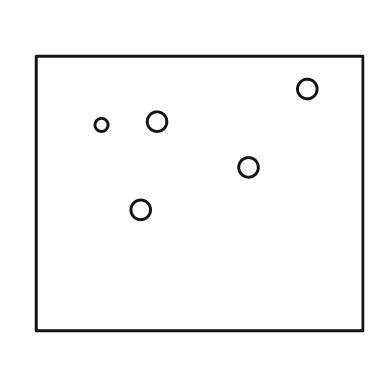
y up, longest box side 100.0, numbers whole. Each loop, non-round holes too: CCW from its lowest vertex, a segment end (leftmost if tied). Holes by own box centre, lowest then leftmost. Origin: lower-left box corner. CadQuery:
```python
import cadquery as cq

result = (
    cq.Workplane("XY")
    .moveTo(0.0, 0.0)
    .lineTo(100.0, 0.0)
    .lineTo(100.0, 84.0)
    .lineTo(0.0, 84.0)
    .close()
    .moveTo(32.0, 37.0)
    .circle(3.0)
    .moveTo(65.0, 50.0)
    .circle(3.0)
    .moveTo(20.0, 63.0)
    .circle(2.0)
    .moveTo(37.0, 64.0)
    .circle(3.0)
    .moveTo(83.0, 74.0)
    .circle(3.0)
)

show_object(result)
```